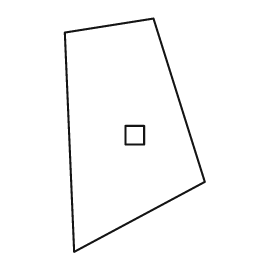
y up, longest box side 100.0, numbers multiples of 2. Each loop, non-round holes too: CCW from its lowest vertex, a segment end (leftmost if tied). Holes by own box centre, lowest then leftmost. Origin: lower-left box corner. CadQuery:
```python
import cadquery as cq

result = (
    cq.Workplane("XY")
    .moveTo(4.0, 0.0)
    .lineTo(60.0, 30.0)
    .lineTo(38.0, 100.0)
    .lineTo(0.0, 94.0)
    .close()
    .moveTo(26.0, 46.0)
    .lineTo(34.0, 46.0)
    .lineTo(34.0, 54.0)
    .lineTo(26.0, 54.0)
    .close()
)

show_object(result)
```